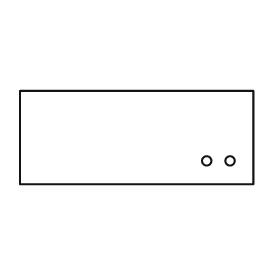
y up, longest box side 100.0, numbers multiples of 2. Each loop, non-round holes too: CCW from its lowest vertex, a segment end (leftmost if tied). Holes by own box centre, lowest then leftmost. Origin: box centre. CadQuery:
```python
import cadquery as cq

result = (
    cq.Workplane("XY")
    .moveTo(-50.0, -20.0)
    .lineTo(50.0, -20.0)
    .lineTo(50.0, 20.0)
    .lineTo(-50.0, 20.0)
    .close()
    .moveTo(30.0, -10.0)
    .circle(2.0)
    .moveTo(40.0, -10.0)
    .circle(2.0)
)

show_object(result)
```